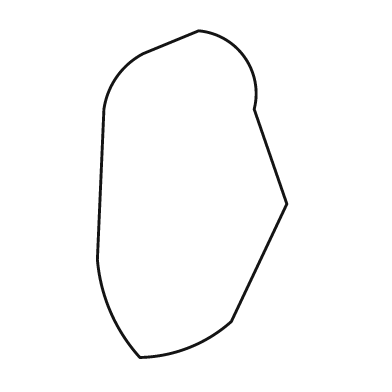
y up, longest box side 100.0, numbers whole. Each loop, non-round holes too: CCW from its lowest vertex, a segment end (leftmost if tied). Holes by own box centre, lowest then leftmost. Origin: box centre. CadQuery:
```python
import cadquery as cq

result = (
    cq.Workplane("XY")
    .moveTo(-16.0, -50.0)
    .threePointArc((-1.0, -47.0), (12.0, -39.0))
    .lineTo(29.0, -3.0)
    .lineTo(19.0, 26.0)
    .threePointArc((16.0, 42.0), (2.0, 50.0))
    .lineTo(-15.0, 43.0)
    .threePointArc((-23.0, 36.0), (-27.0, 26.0))
    .lineTo(-29.0, -20.0)
    .threePointArc((-25.0, -36.0), (-16.0, -50.0))
    .close()
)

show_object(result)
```